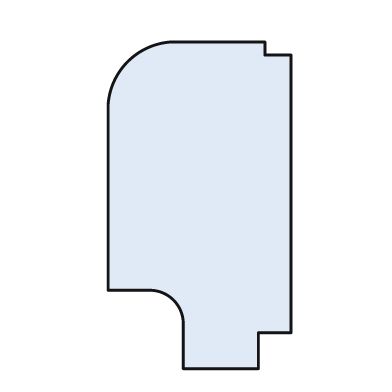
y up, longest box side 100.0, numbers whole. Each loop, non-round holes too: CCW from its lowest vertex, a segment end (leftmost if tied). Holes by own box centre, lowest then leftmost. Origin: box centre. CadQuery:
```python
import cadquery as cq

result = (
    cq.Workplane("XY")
    .moveTo(-5.0, -50.0)
    .lineTo(18.0, -50.0)
    .lineTo(18.0, -39.0)
    .lineTo(28.0, -39.0)
    .lineTo(28.0, 46.0)
    .lineTo(20.0, 46.0)
    .lineTo(20.0, 50.0)
    .lineTo(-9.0, 50.0)
    .threePointArc((-22.0, 44.0), (-28.0, 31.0))
    .lineTo(-28.0, -26.0)
    .lineTo(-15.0, -26.0)
    .threePointArc((-8.0, -29.0), (-5.0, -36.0))
    .close()
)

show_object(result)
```